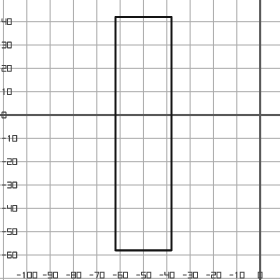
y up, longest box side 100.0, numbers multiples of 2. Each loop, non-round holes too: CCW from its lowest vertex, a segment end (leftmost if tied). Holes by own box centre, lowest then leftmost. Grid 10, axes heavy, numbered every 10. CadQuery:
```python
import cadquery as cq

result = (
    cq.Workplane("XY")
    .moveTo(-62.0, -58.0)
    .lineTo(-38.0, -58.0)
    .lineTo(-38.0, 42.0)
    .lineTo(-62.0, 42.0)
    .close()
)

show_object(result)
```